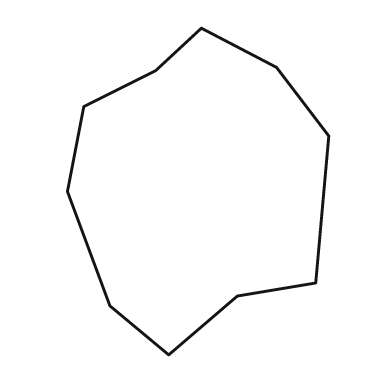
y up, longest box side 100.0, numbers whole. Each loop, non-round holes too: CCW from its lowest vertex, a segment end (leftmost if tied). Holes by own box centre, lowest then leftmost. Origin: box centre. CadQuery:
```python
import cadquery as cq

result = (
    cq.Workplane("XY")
    .moveTo(-9.0, -50.0)
    .lineTo(12.0, -32.0)
    .lineTo(36.0, -28.0)
    .lineTo(40.0, 17.0)
    .lineTo(24.0, 38.0)
    .lineTo(1.0, 50.0)
    .lineTo(-13.0, 37.0)
    .lineTo(-35.0, 26.0)
    .lineTo(-40.0, 0.0)
    .lineTo(-27.0, -35.0)
    .close()
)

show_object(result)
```